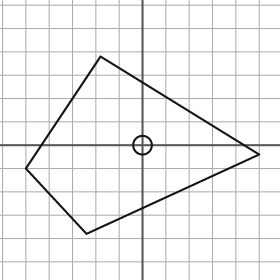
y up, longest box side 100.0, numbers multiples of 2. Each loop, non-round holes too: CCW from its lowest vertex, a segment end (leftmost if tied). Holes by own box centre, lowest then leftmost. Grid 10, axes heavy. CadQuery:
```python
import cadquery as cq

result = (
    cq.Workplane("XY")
    .moveTo(-24.0, -38.0)
    .lineTo(50.0, -4.0)
    .lineTo(-18.0, 38.0)
    .lineTo(-50.0, -10.0)
    .close()
    .moveTo(0.0, 0.0)
    .circle(4.0)
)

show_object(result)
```